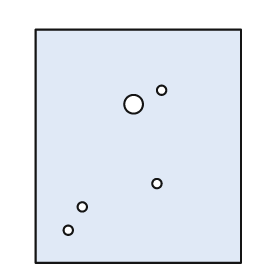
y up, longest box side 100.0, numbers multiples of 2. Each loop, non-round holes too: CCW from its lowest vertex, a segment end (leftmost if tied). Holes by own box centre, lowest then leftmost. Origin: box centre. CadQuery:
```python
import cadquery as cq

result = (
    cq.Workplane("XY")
    .moveTo(-44.0, -50.0)
    .lineTo(44.0, -50.0)
    .lineTo(44.0, 50.0)
    .lineTo(-44.0, 50.0)
    .close()
    .moveTo(-30.0, -36.0)
    .circle(2.0)
    .moveTo(-24.0, -26.0)
    .circle(2.0)
    .moveTo(8.0, -16.0)
    .circle(2.0)
    .moveTo(-2.0, 18.0)
    .circle(4.0)
    .moveTo(10.0, 24.0)
    .circle(2.0)
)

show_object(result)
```